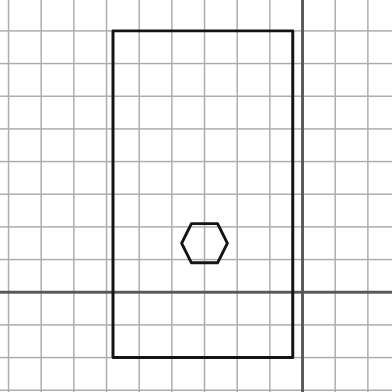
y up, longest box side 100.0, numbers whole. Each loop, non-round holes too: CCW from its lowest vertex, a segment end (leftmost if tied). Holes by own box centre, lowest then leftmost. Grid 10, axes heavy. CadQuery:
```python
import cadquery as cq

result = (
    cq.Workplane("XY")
    .moveTo(-58.0, -20.0)
    .lineTo(-3.0, -20.0)
    .lineTo(-3.0, 80.0)
    .lineTo(-58.0, 80.0)
    .close()
    .moveTo(-34.0, 9.0)
    .lineTo(-26.0, 9.0)
    .lineTo(-23.0, 15.0)
    .lineTo(-26.0, 21.0)
    .lineTo(-34.0, 21.0)
    .lineTo(-37.0, 15.0)
    .close()
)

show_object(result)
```